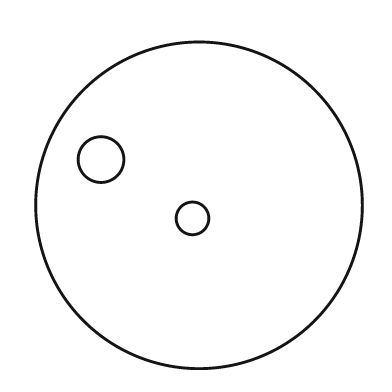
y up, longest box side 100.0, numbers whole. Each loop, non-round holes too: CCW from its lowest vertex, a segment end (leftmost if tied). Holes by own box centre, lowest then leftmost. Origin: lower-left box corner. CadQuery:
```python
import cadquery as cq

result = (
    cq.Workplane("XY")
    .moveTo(50.0, 50.0)
    .circle(50.0)
    .moveTo(48.0, 46.0)
    .circle(5.0)
    .moveTo(20.0, 64.0)
    .circle(7.0)
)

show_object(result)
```